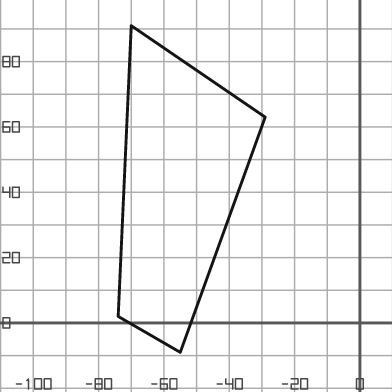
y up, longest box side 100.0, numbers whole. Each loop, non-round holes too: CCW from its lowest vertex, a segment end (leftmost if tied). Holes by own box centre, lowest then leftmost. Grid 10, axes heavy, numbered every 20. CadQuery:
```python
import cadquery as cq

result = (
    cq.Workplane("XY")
    .moveTo(-55.0, -9.0)
    .lineTo(-29.0, 63.0)
    .lineTo(-70.0, 91.0)
    .lineTo(-74.0, 2.0)
    .close()
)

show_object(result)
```